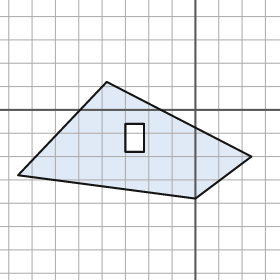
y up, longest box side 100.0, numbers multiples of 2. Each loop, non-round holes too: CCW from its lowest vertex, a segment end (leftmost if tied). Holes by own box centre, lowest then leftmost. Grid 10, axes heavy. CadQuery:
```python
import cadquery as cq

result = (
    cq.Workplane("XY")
    .moveTo(0.0, -38.0)
    .lineTo(24.0, -20.0)
    .lineTo(-38.0, 12.0)
    .lineTo(-76.0, -28.0)
    .close()
    .moveTo(-30.0, -18.0)
    .lineTo(-22.0, -18.0)
    .lineTo(-22.0, -6.0)
    .lineTo(-30.0, -6.0)
    .close()
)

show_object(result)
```